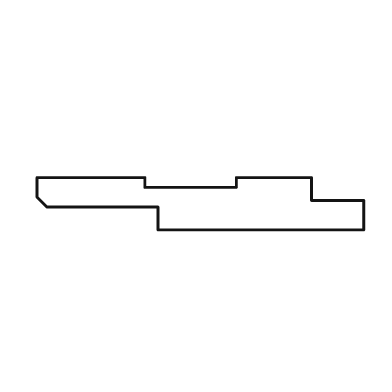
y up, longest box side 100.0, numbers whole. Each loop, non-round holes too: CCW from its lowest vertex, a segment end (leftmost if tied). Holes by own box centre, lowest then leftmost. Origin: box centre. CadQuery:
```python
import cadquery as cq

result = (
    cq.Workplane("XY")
    .moveTo(-13.0, -8.0)
    .lineTo(50.0, -8.0)
    .lineTo(50.0, 1.0)
    .lineTo(34.0, 1.0)
    .lineTo(34.0, 8.0)
    .lineTo(11.0, 8.0)
    .lineTo(11.0, 5.0)
    .lineTo(-17.0, 5.0)
    .lineTo(-17.0, 8.0)
    .lineTo(-50.0, 8.0)
    .lineTo(-50.0, 2.0)
    .lineTo(-47.0, -1.0)
    .lineTo(-13.0, -1.0)
    .close()
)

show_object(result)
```